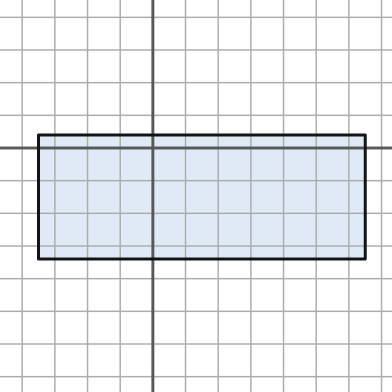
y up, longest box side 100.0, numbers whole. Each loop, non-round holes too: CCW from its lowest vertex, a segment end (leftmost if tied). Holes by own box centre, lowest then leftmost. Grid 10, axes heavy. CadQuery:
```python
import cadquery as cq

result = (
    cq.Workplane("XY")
    .moveTo(-35.0, -34.0)
    .lineTo(65.0, -34.0)
    .lineTo(65.0, 4.0)
    .lineTo(-35.0, 4.0)
    .close()
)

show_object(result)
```